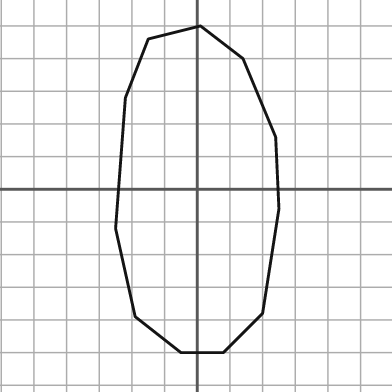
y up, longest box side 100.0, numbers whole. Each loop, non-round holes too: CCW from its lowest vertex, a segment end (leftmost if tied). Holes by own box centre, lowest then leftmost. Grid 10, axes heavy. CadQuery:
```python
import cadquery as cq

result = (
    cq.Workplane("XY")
    .moveTo(-5.0, -50.0)
    .lineTo(8.0, -50.0)
    .lineTo(20.0, -38.0)
    .lineTo(25.0, -6.0)
    .lineTo(24.0, 16.0)
    .lineTo(14.0, 40.0)
    .lineTo(1.0, 50.0)
    .lineTo(-15.0, 46.0)
    .lineTo(-22.0, 28.0)
    .lineTo(-25.0, -12.0)
    .lineTo(-19.0, -39.0)
    .close()
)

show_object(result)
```